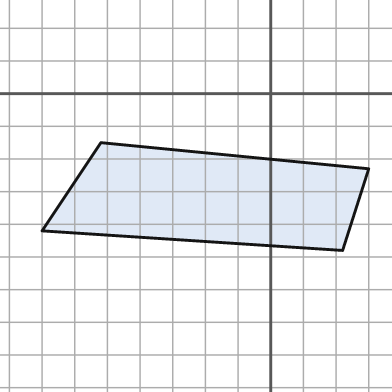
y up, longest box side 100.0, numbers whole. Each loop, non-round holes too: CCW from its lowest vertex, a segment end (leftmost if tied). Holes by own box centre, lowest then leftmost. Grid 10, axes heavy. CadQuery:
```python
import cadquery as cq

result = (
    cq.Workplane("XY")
    .moveTo(22.0, -48.0)
    .lineTo(30.0, -23.0)
    .lineTo(-52.0, -15.0)
    .lineTo(-70.0, -42.0)
    .close()
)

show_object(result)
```